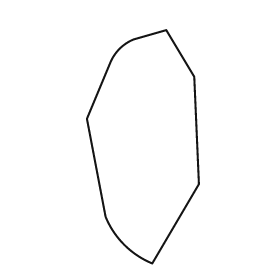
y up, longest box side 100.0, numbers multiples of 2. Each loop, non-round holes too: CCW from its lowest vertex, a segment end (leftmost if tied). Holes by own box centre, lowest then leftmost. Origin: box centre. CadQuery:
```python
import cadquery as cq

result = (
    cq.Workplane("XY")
    .moveTo(4.0, -50.0)
    .lineTo(24.0, -16.0)
    .lineTo(22.0, 30.0)
    .lineTo(10.0, 50.0)
    .lineTo(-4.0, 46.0)
    .threePointArc((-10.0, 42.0), (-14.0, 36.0))
    .lineTo(-24.0, 12.0)
    .lineTo(-16.0, -30.0)
    .threePointArc((-8.0, -42.0), (4.0, -50.0))
    .close()
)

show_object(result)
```